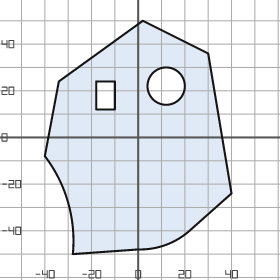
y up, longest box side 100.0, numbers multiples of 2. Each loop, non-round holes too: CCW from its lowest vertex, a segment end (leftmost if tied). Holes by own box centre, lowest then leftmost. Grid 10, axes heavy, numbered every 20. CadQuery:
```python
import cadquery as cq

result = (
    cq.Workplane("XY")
    .moveTo(-28.0, -50.0)
    .lineTo(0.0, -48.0)
    .threePointArc((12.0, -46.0), (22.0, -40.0))
    .lineTo(40.0, -24.0)
    .lineTo(30.0, 36.0)
    .lineTo(2.0, 50.0)
    .lineTo(-34.0, 24.0)
    .lineTo(-40.0, -8.0)
    .threePointArc((-30.0, -28.0), (-28.0, -50.0))
    .close()
    .moveTo(-18.0, 12.0)
    .lineTo(-10.0, 12.0)
    .lineTo(-10.0, 24.0)
    .lineTo(-18.0, 24.0)
    .close()
    .moveTo(12.0, 22.0)
    .circle(8.0)
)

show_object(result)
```